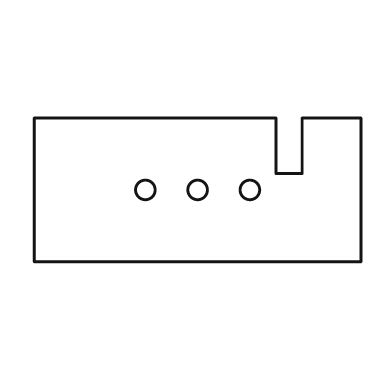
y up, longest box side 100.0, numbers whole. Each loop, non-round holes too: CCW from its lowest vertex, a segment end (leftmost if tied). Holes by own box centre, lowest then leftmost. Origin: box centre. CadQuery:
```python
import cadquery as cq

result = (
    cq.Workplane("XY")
    .moveTo(-50.0, -22.0)
    .lineTo(50.0, -22.0)
    .lineTo(50.0, 22.0)
    .lineTo(32.0, 22.0)
    .lineTo(32.0, 5.0)
    .lineTo(24.0, 5.0)
    .lineTo(24.0, 22.0)
    .lineTo(-50.0, 22.0)
    .close()
    .moveTo(-16.0, 0.0)
    .circle(3.0)
    .moveTo(0.0, 0.0)
    .circle(3.0)
    .moveTo(16.0, 0.0)
    .circle(3.0)
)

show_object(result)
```